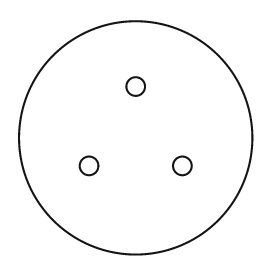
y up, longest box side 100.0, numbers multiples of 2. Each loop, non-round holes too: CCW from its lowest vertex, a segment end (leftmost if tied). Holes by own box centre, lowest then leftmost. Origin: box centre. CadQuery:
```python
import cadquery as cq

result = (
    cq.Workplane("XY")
    .moveTo(0.0, 0.0)
    .circle(50.0)
    .moveTo(-20.0, -12.0)
    .circle(4.0)
    .moveTo(20.0, -12.0)
    .circle(4.0)
    .moveTo(0.0, 22.0)
    .circle(4.0)
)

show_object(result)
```